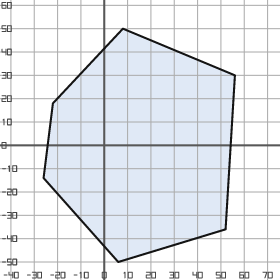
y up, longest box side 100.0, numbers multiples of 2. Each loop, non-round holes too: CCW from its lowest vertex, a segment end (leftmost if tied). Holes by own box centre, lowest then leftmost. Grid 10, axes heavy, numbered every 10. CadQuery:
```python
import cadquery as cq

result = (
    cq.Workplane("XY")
    .moveTo(6.0, -50.0)
    .lineTo(52.0, -36.0)
    .lineTo(56.0, 30.0)
    .lineTo(8.0, 50.0)
    .lineTo(-22.0, 18.0)
    .lineTo(-26.0, -14.0)
    .close()
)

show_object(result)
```